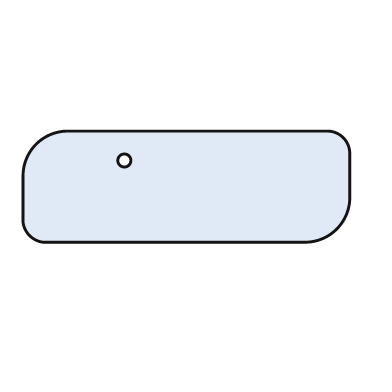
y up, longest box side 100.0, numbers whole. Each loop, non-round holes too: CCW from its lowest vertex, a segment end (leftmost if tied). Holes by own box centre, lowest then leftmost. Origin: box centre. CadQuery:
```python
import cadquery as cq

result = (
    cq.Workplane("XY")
    .moveTo(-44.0, -17.0)
    .lineTo(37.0, -17.0)
    .threePointArc((46.0, -13.0), (50.0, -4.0))
    .lineTo(50.0, 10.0)
    .threePointArc((48.0, 15.0), (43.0, 17.0))
    .lineTo(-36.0, 17.0)
    .threePointArc((-46.0, 13.0), (-50.0, 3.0))
    .lineTo(-50.0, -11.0)
    .threePointArc((-48.0, -15.0), (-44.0, -17.0))
    .close()
    .moveTo(-19.0, 8.0)
    .circle(2.0)
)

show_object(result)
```